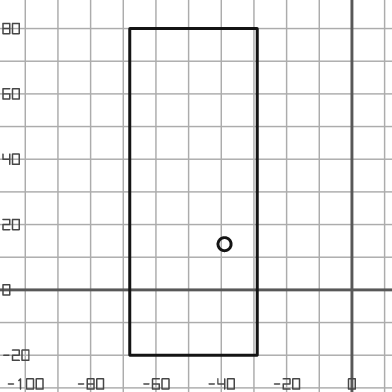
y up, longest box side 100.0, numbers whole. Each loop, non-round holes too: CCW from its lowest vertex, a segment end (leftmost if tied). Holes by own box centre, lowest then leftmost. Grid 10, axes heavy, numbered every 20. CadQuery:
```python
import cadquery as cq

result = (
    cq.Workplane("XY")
    .moveTo(-68.0, -20.0)
    .lineTo(-29.0, -20.0)
    .lineTo(-29.0, 80.0)
    .lineTo(-68.0, 80.0)
    .close()
    .moveTo(-39.0, 14.0)
    .circle(2.0)
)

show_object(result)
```